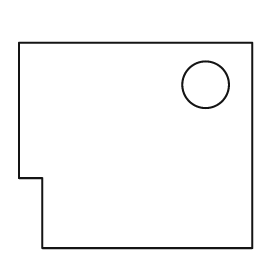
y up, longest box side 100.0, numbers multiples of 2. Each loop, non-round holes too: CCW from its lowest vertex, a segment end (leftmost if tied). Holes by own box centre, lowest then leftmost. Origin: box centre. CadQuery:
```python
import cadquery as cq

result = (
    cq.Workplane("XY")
    .moveTo(-40.0, -44.0)
    .lineTo(50.0, -44.0)
    .lineTo(50.0, 44.0)
    .lineTo(-50.0, 44.0)
    .lineTo(-50.0, -14.0)
    .lineTo(-40.0, -14.0)
    .close()
    .moveTo(30.0, 26.0)
    .circle(10.0)
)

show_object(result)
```